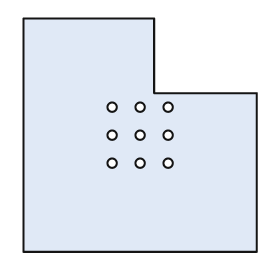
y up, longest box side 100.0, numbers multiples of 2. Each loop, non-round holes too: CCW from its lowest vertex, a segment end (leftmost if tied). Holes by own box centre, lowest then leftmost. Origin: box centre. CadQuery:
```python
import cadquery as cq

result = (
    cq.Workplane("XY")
    .moveTo(-50.0, -50.0)
    .lineTo(50.0, -50.0)
    .lineTo(50.0, 18.0)
    .lineTo(6.0, 18.0)
    .lineTo(6.0, 50.0)
    .lineTo(-50.0, 50.0)
    .close()
    .moveTo(-12.0, -12.0)
    .circle(2.0)
    .moveTo(0.0, -12.0)
    .circle(2.0)
    .moveTo(12.0, -12.0)
    .circle(2.0)
    .moveTo(-12.0, 0.0)
    .circle(2.0)
    .moveTo(0.0, 0.0)
    .circle(2.0)
    .moveTo(12.0, 0.0)
    .circle(2.0)
    .moveTo(-12.0, 12.0)
    .circle(2.0)
    .moveTo(0.0, 12.0)
    .circle(2.0)
    .moveTo(12.0, 12.0)
    .circle(2.0)
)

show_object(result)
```